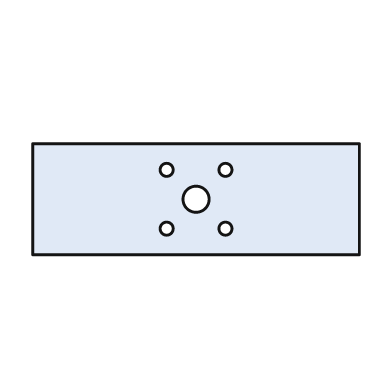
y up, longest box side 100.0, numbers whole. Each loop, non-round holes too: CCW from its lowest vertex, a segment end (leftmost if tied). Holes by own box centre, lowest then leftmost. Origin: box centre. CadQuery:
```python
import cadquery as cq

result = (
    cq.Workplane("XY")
    .moveTo(-50.0, -17.0)
    .lineTo(50.0, -17.0)
    .lineTo(50.0, 17.0)
    .lineTo(-50.0, 17.0)
    .close()
    .moveTo(-9.0, -9.0)
    .circle(2.0)
    .moveTo(9.0, -9.0)
    .circle(2.0)
    .moveTo(0.0, 0.0)
    .circle(4.0)
    .moveTo(-9.0, 9.0)
    .circle(2.0)
    .moveTo(9.0, 9.0)
    .circle(2.0)
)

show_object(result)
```